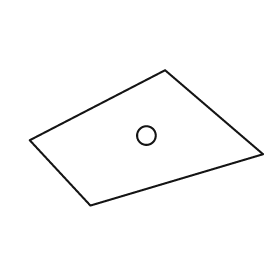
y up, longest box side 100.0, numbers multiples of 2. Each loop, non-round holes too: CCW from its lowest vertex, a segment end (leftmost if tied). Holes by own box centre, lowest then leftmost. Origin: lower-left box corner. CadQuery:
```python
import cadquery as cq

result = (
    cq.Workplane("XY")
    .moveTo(26.0, 0.0)
    .lineTo(100.0, 22.0)
    .lineTo(58.0, 58.0)
    .lineTo(0.0, 28.0)
    .close()
    .moveTo(50.0, 30.0)
    .circle(4.0)
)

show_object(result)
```